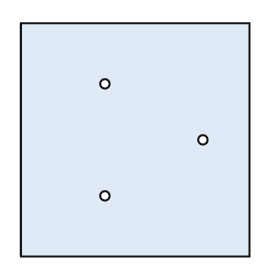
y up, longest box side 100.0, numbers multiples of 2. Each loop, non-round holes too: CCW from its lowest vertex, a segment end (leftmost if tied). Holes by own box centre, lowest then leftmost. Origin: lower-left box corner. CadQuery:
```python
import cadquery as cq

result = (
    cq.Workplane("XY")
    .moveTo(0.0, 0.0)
    .lineTo(98.0, 0.0)
    .lineTo(98.0, 100.0)
    .lineTo(0.0, 100.0)
    .close()
    .moveTo(36.0, 26.0)
    .circle(2.0)
    .moveTo(78.0, 50.0)
    .circle(2.0)
    .moveTo(36.0, 74.0)
    .circle(2.0)
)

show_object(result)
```